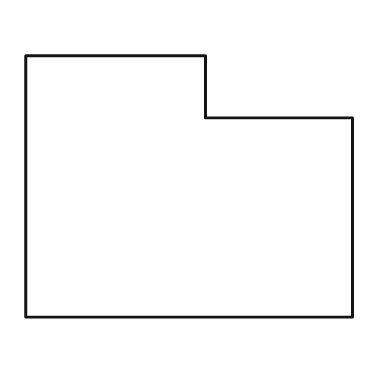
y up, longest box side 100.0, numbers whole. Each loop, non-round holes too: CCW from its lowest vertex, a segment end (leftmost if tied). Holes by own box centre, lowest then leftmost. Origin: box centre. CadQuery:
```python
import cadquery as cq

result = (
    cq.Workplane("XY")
    .moveTo(-50.0, -40.0)
    .lineTo(50.0, -40.0)
    .lineTo(50.0, 21.0)
    .lineTo(5.0, 21.0)
    .lineTo(5.0, 40.0)
    .lineTo(-50.0, 40.0)
    .close()
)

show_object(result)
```